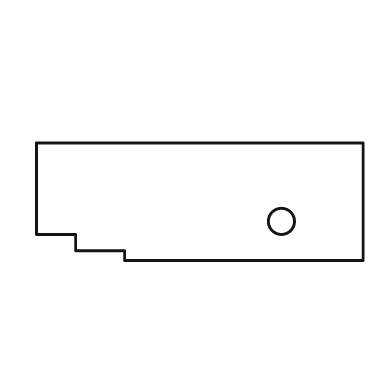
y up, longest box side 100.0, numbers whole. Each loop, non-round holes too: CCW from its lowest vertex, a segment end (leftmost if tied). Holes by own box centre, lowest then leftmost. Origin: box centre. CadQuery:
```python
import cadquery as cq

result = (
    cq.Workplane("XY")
    .moveTo(-23.0, -18.0)
    .lineTo(50.0, -18.0)
    .lineTo(50.0, 18.0)
    .lineTo(-50.0, 18.0)
    .lineTo(-50.0, -10.0)
    .lineTo(-38.0, -10.0)
    .lineTo(-38.0, -15.0)
    .lineTo(-23.0, -15.0)
    .close()
    .moveTo(25.0, -6.0)
    .circle(4.0)
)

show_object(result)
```